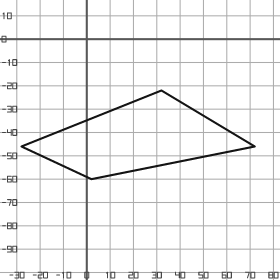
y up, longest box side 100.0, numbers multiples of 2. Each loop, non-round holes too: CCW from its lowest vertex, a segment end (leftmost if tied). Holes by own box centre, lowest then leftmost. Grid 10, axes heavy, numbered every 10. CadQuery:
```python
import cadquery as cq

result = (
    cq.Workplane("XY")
    .moveTo(2.0, -60.0)
    .lineTo(72.0, -46.0)
    .lineTo(32.0, -22.0)
    .lineTo(-28.0, -46.0)
    .close()
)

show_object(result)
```